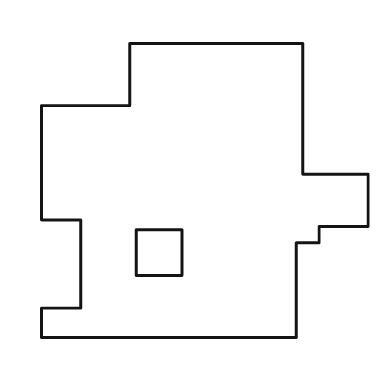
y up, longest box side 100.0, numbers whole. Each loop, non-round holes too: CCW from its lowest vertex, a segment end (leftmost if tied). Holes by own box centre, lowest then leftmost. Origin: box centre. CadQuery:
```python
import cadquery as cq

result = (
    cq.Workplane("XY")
    .moveTo(-50.0, -45.0)
    .lineTo(28.0, -45.0)
    .lineTo(28.0, -16.0)
    .lineTo(35.0, -16.0)
    .lineTo(35.0, -11.0)
    .lineTo(50.0, -11.0)
    .lineTo(50.0, 5.0)
    .lineTo(30.0, 5.0)
    .lineTo(30.0, 45.0)
    .lineTo(-23.0, 45.0)
    .lineTo(-23.0, 26.0)
    .lineTo(-50.0, 26.0)
    .lineTo(-50.0, -9.0)
    .lineTo(-38.0, -9.0)
    .lineTo(-38.0, -36.0)
    .lineTo(-50.0, -36.0)
    .close()
    .moveTo(-21.0, -26.0)
    .lineTo(-7.0, -26.0)
    .lineTo(-7.0, -12.0)
    .lineTo(-21.0, -12.0)
    .close()
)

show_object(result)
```